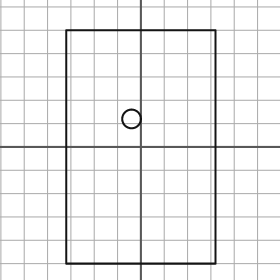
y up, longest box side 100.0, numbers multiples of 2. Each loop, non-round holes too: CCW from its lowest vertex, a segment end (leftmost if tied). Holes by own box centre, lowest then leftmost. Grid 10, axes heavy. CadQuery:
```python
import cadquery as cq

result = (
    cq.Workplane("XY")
    .moveTo(-32.0, -50.0)
    .lineTo(32.0, -50.0)
    .lineTo(32.0, 50.0)
    .lineTo(-32.0, 50.0)
    .close()
    .moveTo(-4.0, 12.0)
    .circle(4.0)
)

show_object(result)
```